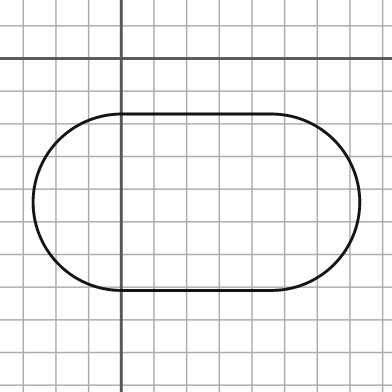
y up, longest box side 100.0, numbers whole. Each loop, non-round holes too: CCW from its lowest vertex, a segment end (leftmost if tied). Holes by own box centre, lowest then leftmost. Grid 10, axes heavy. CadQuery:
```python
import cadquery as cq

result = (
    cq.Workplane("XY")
    .moveTo(0.0, -71.0)
    .lineTo(46.0, -71.0)
    .threePointArc((73.0, -44.0), (46.0, -17.0))
    .lineTo(0.0, -17.0)
    .threePointArc((-27.0, -44.0), (0.0, -71.0))
    .close()
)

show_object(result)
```